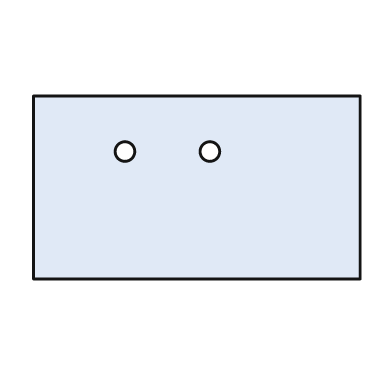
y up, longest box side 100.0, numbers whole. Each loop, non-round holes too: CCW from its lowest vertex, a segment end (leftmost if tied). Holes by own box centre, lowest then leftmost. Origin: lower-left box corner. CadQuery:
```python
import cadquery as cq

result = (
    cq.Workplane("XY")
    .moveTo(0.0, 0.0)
    .lineTo(100.0, 0.0)
    .lineTo(100.0, 56.0)
    .lineTo(0.0, 56.0)
    .close()
    .moveTo(28.0, 39.0)
    .circle(3.0)
    .moveTo(54.0, 39.0)
    .circle(3.0)
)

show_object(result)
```